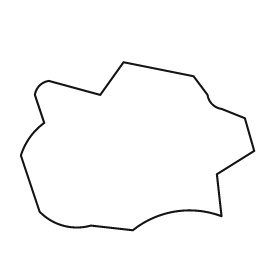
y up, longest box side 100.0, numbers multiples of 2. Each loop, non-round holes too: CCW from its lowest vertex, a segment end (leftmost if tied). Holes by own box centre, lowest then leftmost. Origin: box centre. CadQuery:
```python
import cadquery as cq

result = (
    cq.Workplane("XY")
    .moveTo(-2.0, -36.0)
    .threePointArc((16.0, -28.0), (36.0, -30.0))
    .lineTo(34.0, -12.0)
    .lineTo(50.0, -2.0)
    .lineTo(46.0, 12.0)
    .lineTo(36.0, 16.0)
    .threePointArc((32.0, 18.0), (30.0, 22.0))
    .lineTo(24.0, 30.0)
    .lineTo(-6.0, 36.0)
    .lineTo(-16.0, 22.0)
    .lineTo(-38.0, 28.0)
    .threePointArc((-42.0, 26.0), (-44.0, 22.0))
    .lineTo(-40.0, 10.0)
    .threePointArc((-46.0, 4.0), (-50.0, -4.0))
    .lineTo(-42.0, -28.0)
    .threePointArc((-32.0, -34.0), (-20.0, -34.0))
    .close()
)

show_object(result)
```